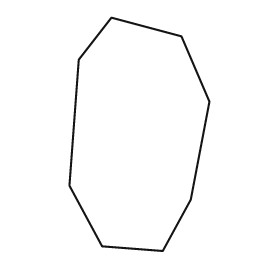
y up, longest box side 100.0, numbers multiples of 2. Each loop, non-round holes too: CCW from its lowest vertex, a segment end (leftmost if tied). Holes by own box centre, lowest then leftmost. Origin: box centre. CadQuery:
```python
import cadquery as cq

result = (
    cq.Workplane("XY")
    .moveTo(10.0, -50.0)
    .lineTo(22.0, -28.0)
    .lineTo(30.0, 14.0)
    .lineTo(18.0, 42.0)
    .lineTo(-12.0, 50.0)
    .lineTo(-26.0, 32.0)
    .lineTo(-30.0, -22.0)
    .lineTo(-16.0, -48.0)
    .close()
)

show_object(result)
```